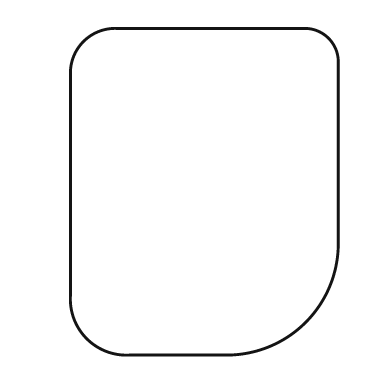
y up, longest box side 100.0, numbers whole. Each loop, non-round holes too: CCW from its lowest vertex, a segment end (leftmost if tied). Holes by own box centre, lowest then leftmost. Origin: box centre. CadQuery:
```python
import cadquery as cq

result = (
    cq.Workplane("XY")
    .moveTo(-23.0, -50.0)
    .lineTo(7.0, -50.0)
    .threePointArc((31.0, -40.0), (41.0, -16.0))
    .lineTo(41.0, 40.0)
    .threePointArc((38.0, 47.0), (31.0, 50.0))
    .lineTo(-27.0, 50.0)
    .threePointArc((-37.0, 46.0), (-41.0, 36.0))
    .lineTo(-41.0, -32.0)
    .threePointArc((-36.0, -45.0), (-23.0, -50.0))
    .close()
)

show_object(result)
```